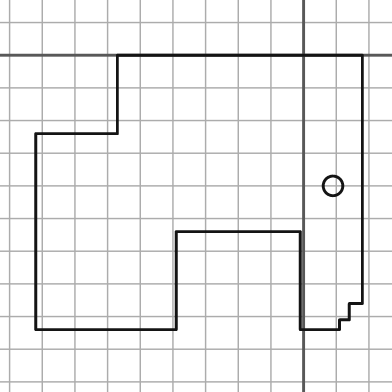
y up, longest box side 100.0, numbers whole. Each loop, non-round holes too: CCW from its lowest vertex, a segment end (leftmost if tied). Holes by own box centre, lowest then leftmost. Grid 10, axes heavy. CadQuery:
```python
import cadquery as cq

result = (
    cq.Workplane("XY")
    .moveTo(-82.0, -84.0)
    .lineTo(-39.0, -84.0)
    .lineTo(-39.0, -54.0)
    .lineTo(-1.0, -54.0)
    .lineTo(-1.0, -84.0)
    .lineTo(11.0, -84.0)
    .lineTo(11.0, -81.0)
    .lineTo(14.0, -81.0)
    .lineTo(14.0, -76.0)
    .lineTo(18.0, -76.0)
    .lineTo(18.0, 0.0)
    .lineTo(-57.0, 0.0)
    .lineTo(-57.0, -24.0)
    .lineTo(-82.0, -24.0)
    .close()
    .moveTo(9.0, -40.0)
    .circle(3.0)
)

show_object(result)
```